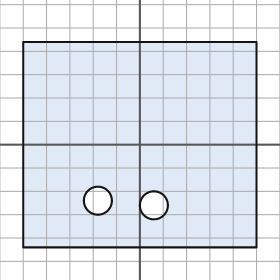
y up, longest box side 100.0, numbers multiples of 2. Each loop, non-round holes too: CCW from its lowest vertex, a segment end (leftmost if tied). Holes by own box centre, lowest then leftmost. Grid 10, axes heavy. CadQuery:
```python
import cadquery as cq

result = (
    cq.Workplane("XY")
    .moveTo(-50.0, -44.0)
    .lineTo(50.0, -44.0)
    .lineTo(50.0, 44.0)
    .lineTo(-50.0, 44.0)
    .close()
    .moveTo(6.0, -26.0)
    .circle(6.0)
    .moveTo(-18.0, -24.0)
    .circle(6.0)
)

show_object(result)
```